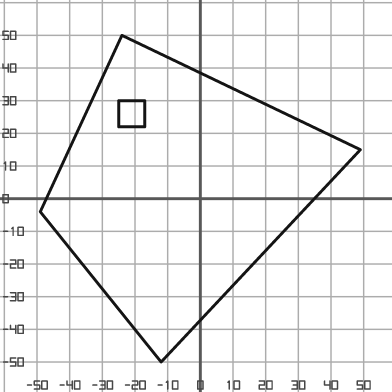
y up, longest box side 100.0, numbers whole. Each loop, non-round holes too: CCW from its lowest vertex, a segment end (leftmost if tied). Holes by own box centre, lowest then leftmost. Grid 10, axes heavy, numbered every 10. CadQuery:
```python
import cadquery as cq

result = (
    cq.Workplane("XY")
    .moveTo(-12.0, -50.0)
    .lineTo(49.0, 15.0)
    .lineTo(-24.0, 50.0)
    .lineTo(-49.0, -4.0)
    .close()
    .moveTo(-25.0, 22.0)
    .lineTo(-17.0, 22.0)
    .lineTo(-17.0, 30.0)
    .lineTo(-25.0, 30.0)
    .close()
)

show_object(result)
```